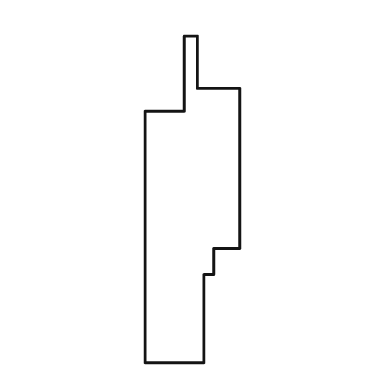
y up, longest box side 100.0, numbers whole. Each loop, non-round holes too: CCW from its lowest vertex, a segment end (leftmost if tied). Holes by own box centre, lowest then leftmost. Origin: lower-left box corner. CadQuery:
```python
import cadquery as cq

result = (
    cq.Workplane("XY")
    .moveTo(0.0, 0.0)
    .lineTo(18.0, 0.0)
    .lineTo(18.0, 27.0)
    .lineTo(21.0, 27.0)
    .lineTo(21.0, 35.0)
    .lineTo(29.0, 35.0)
    .lineTo(29.0, 84.0)
    .lineTo(16.0, 84.0)
    .lineTo(16.0, 100.0)
    .lineTo(12.0, 100.0)
    .lineTo(12.0, 77.0)
    .lineTo(0.0, 77.0)
    .close()
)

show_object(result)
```